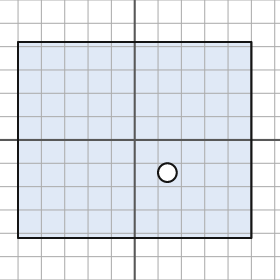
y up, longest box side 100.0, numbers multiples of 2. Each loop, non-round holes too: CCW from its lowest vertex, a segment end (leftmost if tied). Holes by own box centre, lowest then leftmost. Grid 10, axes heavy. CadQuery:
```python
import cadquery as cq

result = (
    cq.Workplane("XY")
    .moveTo(-50.0, -42.0)
    .lineTo(50.0, -42.0)
    .lineTo(50.0, 42.0)
    .lineTo(-50.0, 42.0)
    .close()
    .moveTo(14.0, -14.0)
    .circle(4.0)
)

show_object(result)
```